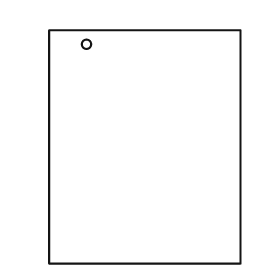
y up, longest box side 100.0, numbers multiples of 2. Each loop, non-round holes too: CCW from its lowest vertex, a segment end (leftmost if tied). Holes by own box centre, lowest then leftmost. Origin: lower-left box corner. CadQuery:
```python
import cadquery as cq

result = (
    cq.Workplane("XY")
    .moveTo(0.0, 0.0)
    .lineTo(82.0, 0.0)
    .lineTo(82.0, 100.0)
    .lineTo(0.0, 100.0)
    .close()
    .moveTo(16.0, 94.0)
    .circle(2.0)
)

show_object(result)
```